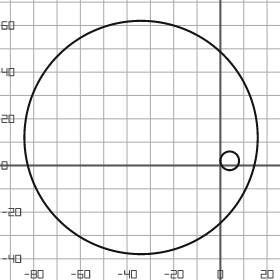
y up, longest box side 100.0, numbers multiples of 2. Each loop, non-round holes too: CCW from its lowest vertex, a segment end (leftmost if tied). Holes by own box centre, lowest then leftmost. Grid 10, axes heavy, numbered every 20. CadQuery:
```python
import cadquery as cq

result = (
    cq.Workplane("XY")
    .moveTo(-34.0, 12.0)
    .circle(50.0)
    .moveTo(4.0, 2.0)
    .circle(4.0)
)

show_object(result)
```